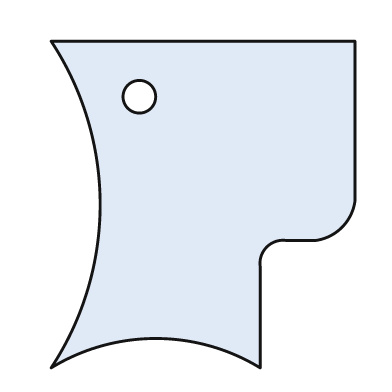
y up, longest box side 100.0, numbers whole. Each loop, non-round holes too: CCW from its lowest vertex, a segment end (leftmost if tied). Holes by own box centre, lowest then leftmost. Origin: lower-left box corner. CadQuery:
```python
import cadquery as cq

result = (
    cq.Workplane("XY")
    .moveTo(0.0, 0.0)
    .threePointArc((32.0, 9.0), (64.0, 0.0))
    .lineTo(64.0, 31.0)
    .threePointArc((66.0, 37.0), (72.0, 39.0))
    .lineTo(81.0, 39.0)
    .threePointArc((89.0, 43.0), (93.0, 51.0))
    .lineTo(93.0, 100.0)
    .lineTo(0.0, 100.0)
    .threePointArc((15.0, 50.0), (0.0, 0.0))
    .close()
    .moveTo(27.0, 83.0)
    .circle(5.0)
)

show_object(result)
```